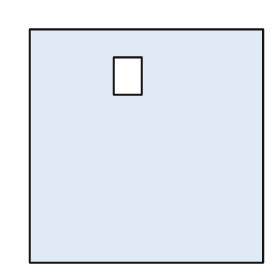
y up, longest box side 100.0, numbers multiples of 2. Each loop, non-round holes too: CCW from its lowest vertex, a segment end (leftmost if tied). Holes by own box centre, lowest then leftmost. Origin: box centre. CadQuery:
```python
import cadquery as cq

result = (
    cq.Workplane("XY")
    .moveTo(-50.0, -50.0)
    .lineTo(50.0, -50.0)
    .lineTo(50.0, 50.0)
    .lineTo(-50.0, 50.0)
    .close()
    .moveTo(-14.0, 22.0)
    .lineTo(-2.0, 22.0)
    .lineTo(-2.0, 38.0)
    .lineTo(-14.0, 38.0)
    .close()
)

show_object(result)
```